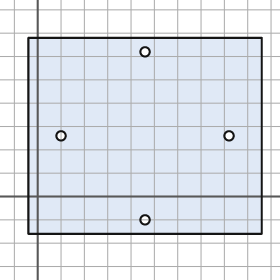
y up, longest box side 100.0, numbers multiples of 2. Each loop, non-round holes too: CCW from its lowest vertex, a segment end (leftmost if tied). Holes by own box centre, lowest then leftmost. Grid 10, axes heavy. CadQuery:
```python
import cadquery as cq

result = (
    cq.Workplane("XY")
    .moveTo(-4.0, -16.0)
    .lineTo(96.0, -16.0)
    .lineTo(96.0, 68.0)
    .lineTo(-4.0, 68.0)
    .close()
    .moveTo(46.0, -10.0)
    .circle(2.0)
    .moveTo(10.0, 26.0)
    .circle(2.0)
    .moveTo(82.0, 26.0)
    .circle(2.0)
    .moveTo(46.0, 62.0)
    .circle(2.0)
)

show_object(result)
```